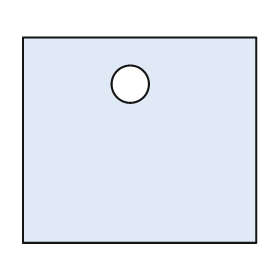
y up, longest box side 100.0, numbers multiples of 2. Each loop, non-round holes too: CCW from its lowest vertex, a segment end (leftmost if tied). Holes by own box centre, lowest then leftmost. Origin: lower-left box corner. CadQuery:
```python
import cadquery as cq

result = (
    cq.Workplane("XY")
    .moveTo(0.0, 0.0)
    .lineTo(100.0, 0.0)
    .lineTo(100.0, 88.0)
    .lineTo(0.0, 88.0)
    .close()
    .moveTo(46.0, 68.0)
    .circle(8.0)
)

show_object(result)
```